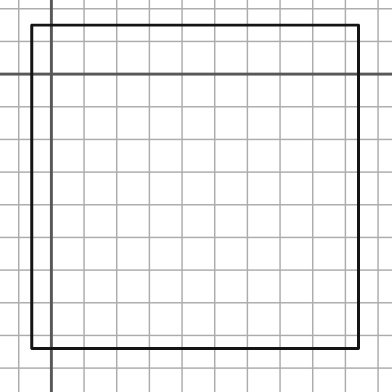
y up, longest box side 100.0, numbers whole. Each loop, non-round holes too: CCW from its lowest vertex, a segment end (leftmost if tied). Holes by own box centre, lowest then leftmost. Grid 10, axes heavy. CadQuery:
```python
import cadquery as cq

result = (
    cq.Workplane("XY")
    .moveTo(-6.0, -84.0)
    .lineTo(94.0, -84.0)
    .lineTo(94.0, 15.0)
    .lineTo(-6.0, 15.0)
    .close()
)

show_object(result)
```